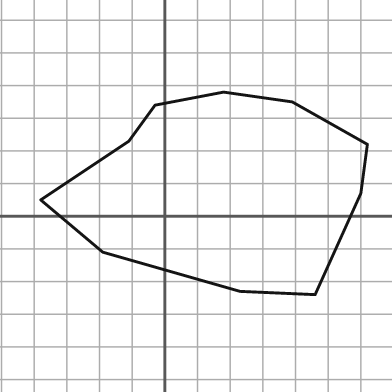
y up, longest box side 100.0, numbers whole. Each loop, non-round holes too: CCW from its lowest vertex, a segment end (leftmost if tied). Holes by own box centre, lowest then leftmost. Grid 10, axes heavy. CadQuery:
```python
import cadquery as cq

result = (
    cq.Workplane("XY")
    .moveTo(46.0, -24.0)
    .lineTo(60.0, 7.0)
    .lineTo(62.0, 22.0)
    .lineTo(39.0, 35.0)
    .lineTo(18.0, 38.0)
    .lineTo(-3.0, 34.0)
    .lineTo(-11.0, 23.0)
    .lineTo(-38.0, 5.0)
    .lineTo(-19.0, -11.0)
    .lineTo(23.0, -23.0)
    .close()
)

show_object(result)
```